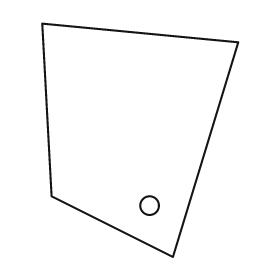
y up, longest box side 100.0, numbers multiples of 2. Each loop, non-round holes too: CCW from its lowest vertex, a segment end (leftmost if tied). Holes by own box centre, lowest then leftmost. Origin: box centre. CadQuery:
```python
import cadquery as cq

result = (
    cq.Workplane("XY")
    .moveTo(14.0, -50.0)
    .lineTo(42.0, 42.0)
    .lineTo(-42.0, 50.0)
    .lineTo(-38.0, -24.0)
    .close()
    .moveTo(4.0, -28.0)
    .circle(4.0)
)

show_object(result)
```